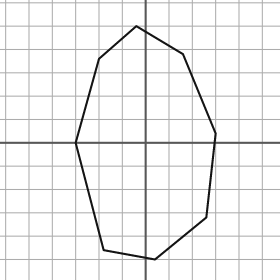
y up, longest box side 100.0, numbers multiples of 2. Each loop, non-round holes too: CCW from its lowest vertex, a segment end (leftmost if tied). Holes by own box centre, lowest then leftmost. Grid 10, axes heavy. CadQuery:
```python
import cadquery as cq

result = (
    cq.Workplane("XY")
    .moveTo(4.0, -50.0)
    .lineTo(26.0, -32.0)
    .lineTo(30.0, 4.0)
    .lineTo(16.0, 38.0)
    .lineTo(-4.0, 50.0)
    .lineTo(-20.0, 36.0)
    .lineTo(-30.0, 0.0)
    .lineTo(-18.0, -46.0)
    .close()
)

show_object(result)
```